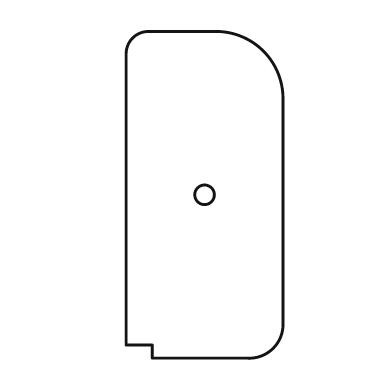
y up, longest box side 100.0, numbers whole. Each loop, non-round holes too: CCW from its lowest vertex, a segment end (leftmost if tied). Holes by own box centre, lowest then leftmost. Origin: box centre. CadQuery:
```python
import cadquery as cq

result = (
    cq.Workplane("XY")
    .moveTo(-16.0, -50.0)
    .lineTo(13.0, -50.0)
    .threePointArc((21.0, -47.0), (24.0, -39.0))
    .lineTo(24.0, 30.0)
    .threePointArc((18.0, 44.0), (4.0, 50.0))
    .lineTo(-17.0, 50.0)
    .threePointArc((-22.0, 48.0), (-24.0, 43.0))
    .lineTo(-24.0, -46.0)
    .lineTo(-16.0, -46.0)
    .close()
    .moveTo(0.0, 0.0)
    .circle(3.0)
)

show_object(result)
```